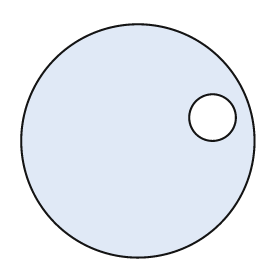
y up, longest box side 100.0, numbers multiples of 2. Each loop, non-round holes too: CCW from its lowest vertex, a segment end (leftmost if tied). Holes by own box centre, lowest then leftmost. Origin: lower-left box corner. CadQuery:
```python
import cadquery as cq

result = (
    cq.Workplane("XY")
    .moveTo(50.0, 50.0)
    .circle(50.0)
    .moveTo(82.0, 60.0)
    .circle(10.0)
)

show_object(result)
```